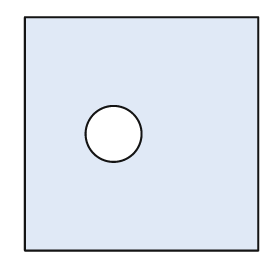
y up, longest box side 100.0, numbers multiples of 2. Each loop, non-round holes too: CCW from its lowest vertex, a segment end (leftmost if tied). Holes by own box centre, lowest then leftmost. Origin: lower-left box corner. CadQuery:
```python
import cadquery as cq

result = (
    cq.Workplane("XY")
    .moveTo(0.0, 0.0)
    .lineTo(100.0, 0.0)
    .lineTo(100.0, 100.0)
    .lineTo(0.0, 100.0)
    .close()
    .moveTo(38.0, 50.0)
    .circle(12.0)
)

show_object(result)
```